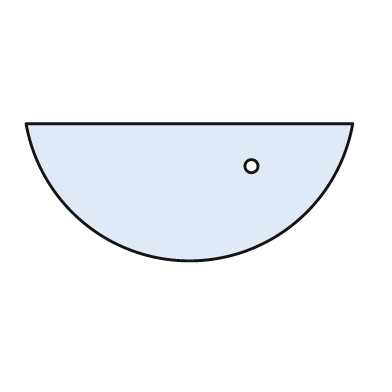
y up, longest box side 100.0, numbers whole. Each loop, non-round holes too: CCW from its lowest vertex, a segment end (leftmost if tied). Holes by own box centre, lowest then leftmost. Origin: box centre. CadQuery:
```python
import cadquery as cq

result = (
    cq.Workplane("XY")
    .moveTo(-50.0, 21.0)
    .threePointArc((0.0, -21.0), (50.0, 21.0))
    .close()
    .moveTo(19.0, 8.0)
    .circle(2.0)
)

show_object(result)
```